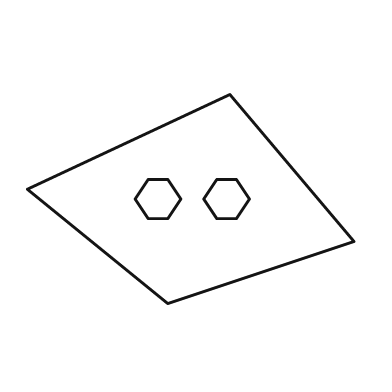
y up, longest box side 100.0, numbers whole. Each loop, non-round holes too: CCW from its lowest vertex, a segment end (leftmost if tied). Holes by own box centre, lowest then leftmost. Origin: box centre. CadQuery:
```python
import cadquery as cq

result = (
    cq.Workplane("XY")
    .moveTo(-7.0, -32.0)
    .lineTo(50.0, -13.0)
    .lineTo(12.0, 32.0)
    .lineTo(-50.0, 3.0)
    .close()
    .moveTo(-13.0, -6.0)
    .lineTo(-7.0, -6.0)
    .lineTo(-3.0, 0.0)
    .lineTo(-7.0, 6.0)
    .lineTo(-13.0, 6.0)
    .lineTo(-17.0, 0.0)
    .close()
    .moveTo(8.0, -6.0)
    .lineTo(14.0, -6.0)
    .lineTo(18.0, 0.0)
    .lineTo(14.0, 6.0)
    .lineTo(8.0, 6.0)
    .lineTo(4.0, 0.0)
    .close()
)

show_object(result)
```